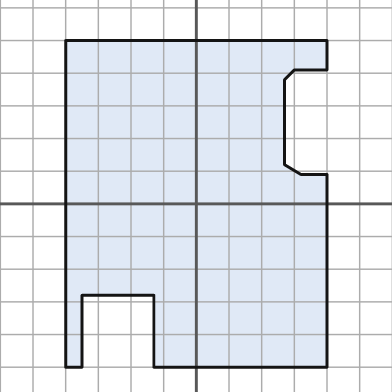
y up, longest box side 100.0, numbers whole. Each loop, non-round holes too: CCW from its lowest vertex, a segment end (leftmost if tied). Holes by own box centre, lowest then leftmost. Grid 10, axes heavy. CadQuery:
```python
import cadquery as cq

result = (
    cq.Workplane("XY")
    .moveTo(-40.0, -50.0)
    .lineTo(-35.0, -50.0)
    .lineTo(-35.0, -28.0)
    .lineTo(-13.0, -28.0)
    .lineTo(-13.0, -50.0)
    .lineTo(40.0, -50.0)
    .lineTo(40.0, 9.0)
    .lineTo(32.0, 9.0)
    .lineTo(27.0, 12.0)
    .lineTo(27.0, 38.0)
    .lineTo(30.0, 41.0)
    .lineTo(40.0, 41.0)
    .lineTo(40.0, 50.0)
    .lineTo(-40.0, 50.0)
    .close()
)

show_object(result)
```